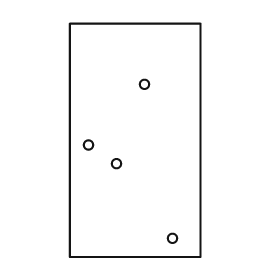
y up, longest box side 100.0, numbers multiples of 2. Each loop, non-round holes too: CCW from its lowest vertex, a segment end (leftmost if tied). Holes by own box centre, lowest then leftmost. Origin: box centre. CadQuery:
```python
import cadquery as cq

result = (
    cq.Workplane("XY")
    .moveTo(-28.0, -50.0)
    .lineTo(28.0, -50.0)
    .lineTo(28.0, 50.0)
    .lineTo(-28.0, 50.0)
    .close()
    .moveTo(16.0, -42.0)
    .circle(2.0)
    .moveTo(-8.0, -10.0)
    .circle(2.0)
    .moveTo(-20.0, -2.0)
    .circle(2.0)
    .moveTo(4.0, 24.0)
    .circle(2.0)
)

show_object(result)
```